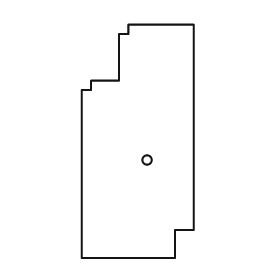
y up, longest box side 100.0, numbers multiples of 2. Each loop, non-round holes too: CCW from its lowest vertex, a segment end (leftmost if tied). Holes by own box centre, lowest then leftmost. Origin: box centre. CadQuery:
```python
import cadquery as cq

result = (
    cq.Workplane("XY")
    .moveTo(-24.0, -50.0)
    .lineTo(16.0, -50.0)
    .lineTo(16.0, -38.0)
    .lineTo(24.0, -38.0)
    .lineTo(24.0, 50.0)
    .lineTo(-4.0, 50.0)
    .lineTo(-4.0, 46.0)
    .lineTo(-8.0, 46.0)
    .lineTo(-8.0, 26.0)
    .lineTo(-20.0, 26.0)
    .lineTo(-20.0, 22.0)
    .lineTo(-24.0, 22.0)
    .close()
    .moveTo(4.0, -8.0)
    .circle(2.0)
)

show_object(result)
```